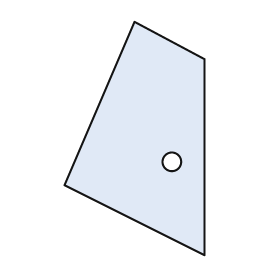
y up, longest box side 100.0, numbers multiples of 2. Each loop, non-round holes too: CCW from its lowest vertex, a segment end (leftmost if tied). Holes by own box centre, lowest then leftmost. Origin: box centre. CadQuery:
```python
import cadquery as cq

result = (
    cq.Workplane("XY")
    .moveTo(30.0, -50.0)
    .lineTo(30.0, 34.0)
    .lineTo(0.0, 50.0)
    .lineTo(-30.0, -20.0)
    .close()
    .moveTo(16.0, -10.0)
    .circle(4.0)
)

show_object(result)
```